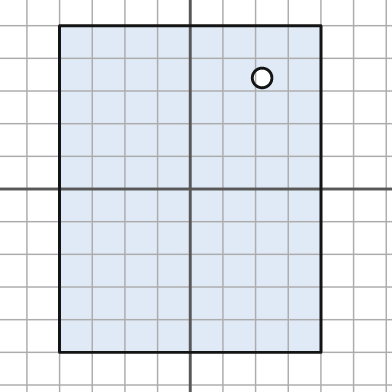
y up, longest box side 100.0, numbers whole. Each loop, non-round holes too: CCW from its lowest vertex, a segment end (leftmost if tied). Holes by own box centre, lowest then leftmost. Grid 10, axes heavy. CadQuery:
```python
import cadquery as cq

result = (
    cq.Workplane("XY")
    .moveTo(-40.0, -50.0)
    .lineTo(40.0, -50.0)
    .lineTo(40.0, 50.0)
    .lineTo(-40.0, 50.0)
    .close()
    .moveTo(22.0, 34.0)
    .circle(3.0)
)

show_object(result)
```